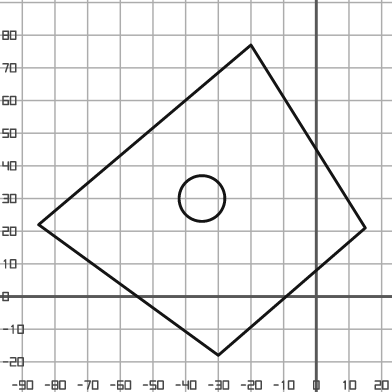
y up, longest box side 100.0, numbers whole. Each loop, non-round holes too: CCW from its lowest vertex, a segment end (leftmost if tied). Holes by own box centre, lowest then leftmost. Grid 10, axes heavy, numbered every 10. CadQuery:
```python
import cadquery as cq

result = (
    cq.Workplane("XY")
    .moveTo(-30.0, -18.0)
    .lineTo(15.0, 21.0)
    .lineTo(-20.0, 77.0)
    .lineTo(-85.0, 22.0)
    .close()
    .moveTo(-35.0, 30.0)
    .circle(7.0)
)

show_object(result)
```